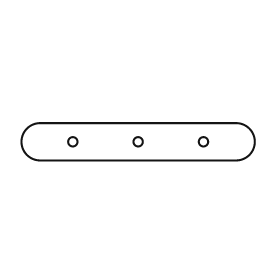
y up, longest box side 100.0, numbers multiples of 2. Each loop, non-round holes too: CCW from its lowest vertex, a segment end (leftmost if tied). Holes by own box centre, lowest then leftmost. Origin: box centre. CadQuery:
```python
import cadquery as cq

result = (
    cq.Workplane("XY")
    .moveTo(-42.0, -8.0)
    .lineTo(42.0, -8.0)
    .threePointArc((50.0, 0.0), (42.0, 8.0))
    .lineTo(-42.0, 8.0)
    .threePointArc((-50.0, 0.0), (-42.0, -8.0))
    .close()
    .moveTo(-28.0, 0.0)
    .circle(2.0)
    .moveTo(0.0, 0.0)
    .circle(2.0)
    .moveTo(28.0, 0.0)
    .circle(2.0)
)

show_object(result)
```